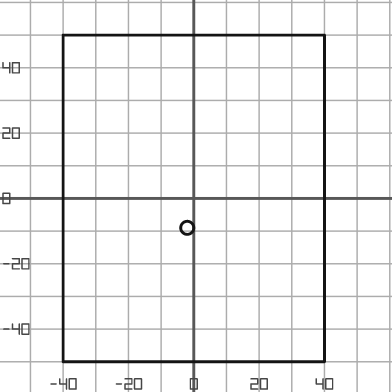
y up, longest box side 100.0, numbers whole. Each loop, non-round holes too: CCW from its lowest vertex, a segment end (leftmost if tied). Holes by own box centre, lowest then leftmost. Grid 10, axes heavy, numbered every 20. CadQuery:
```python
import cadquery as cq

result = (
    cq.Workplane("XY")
    .moveTo(-40.0, -50.0)
    .lineTo(40.0, -50.0)
    .lineTo(40.0, 50.0)
    .lineTo(-40.0, 50.0)
    .close()
    .moveTo(-2.0, -9.0)
    .circle(2.0)
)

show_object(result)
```